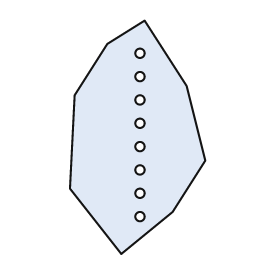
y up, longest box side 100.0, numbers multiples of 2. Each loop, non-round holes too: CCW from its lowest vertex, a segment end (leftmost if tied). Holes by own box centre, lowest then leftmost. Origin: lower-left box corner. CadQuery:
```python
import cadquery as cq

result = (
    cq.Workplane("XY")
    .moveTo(22.0, 0.0)
    .lineTo(44.0, 18.0)
    .lineTo(58.0, 40.0)
    .lineTo(50.0, 72.0)
    .lineTo(32.0, 100.0)
    .lineTo(16.0, 90.0)
    .lineTo(2.0, 68.0)
    .lineTo(0.0, 28.0)
    .close()
    .moveTo(30.0, 16.0)
    .circle(2.0)
    .moveTo(30.0, 26.0)
    .circle(2.0)
    .moveTo(30.0, 36.0)
    .circle(2.0)
    .moveTo(30.0, 46.0)
    .circle(2.0)
    .moveTo(30.0, 56.0)
    .circle(2.0)
    .moveTo(30.0, 66.0)
    .circle(2.0)
    .moveTo(30.0, 76.0)
    .circle(2.0)
    .moveTo(30.0, 86.0)
    .circle(2.0)
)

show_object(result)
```